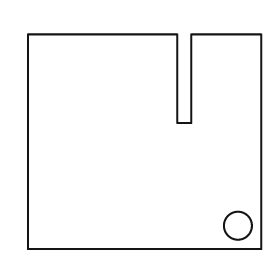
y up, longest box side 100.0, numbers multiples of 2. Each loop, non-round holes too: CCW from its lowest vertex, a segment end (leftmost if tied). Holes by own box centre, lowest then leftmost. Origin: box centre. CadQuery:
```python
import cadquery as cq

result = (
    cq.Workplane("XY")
    .moveTo(-50.0, -46.0)
    .lineTo(50.0, -46.0)
    .lineTo(50.0, 46.0)
    .lineTo(20.0, 46.0)
    .lineTo(20.0, 8.0)
    .lineTo(14.0, 8.0)
    .lineTo(14.0, 46.0)
    .lineTo(-50.0, 46.0)
    .close()
    .moveTo(40.0, -36.0)
    .circle(6.0)
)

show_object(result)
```